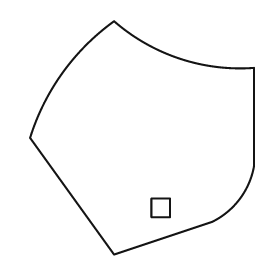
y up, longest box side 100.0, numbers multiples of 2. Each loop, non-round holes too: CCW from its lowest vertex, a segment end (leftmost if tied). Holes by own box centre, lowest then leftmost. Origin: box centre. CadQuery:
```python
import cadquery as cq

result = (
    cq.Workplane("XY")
    .moveTo(-12.0, -50.0)
    .lineTo(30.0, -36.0)
    .threePointArc((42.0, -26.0), (48.0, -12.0))
    .lineTo(48.0, 30.0)
    .threePointArc((16.0, 34.0), (-12.0, 50.0))
    .threePointArc((-34.0, 28.0), (-48.0, 0.0))
    .close()
    .moveTo(4.0, -34.0)
    .lineTo(12.0, -34.0)
    .lineTo(12.0, -26.0)
    .lineTo(4.0, -26.0)
    .close()
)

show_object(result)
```